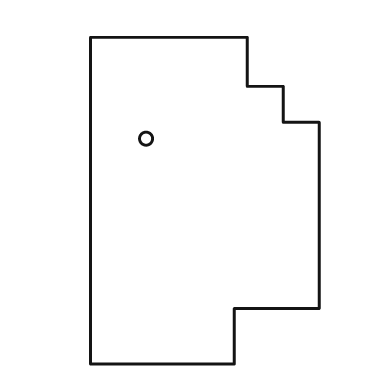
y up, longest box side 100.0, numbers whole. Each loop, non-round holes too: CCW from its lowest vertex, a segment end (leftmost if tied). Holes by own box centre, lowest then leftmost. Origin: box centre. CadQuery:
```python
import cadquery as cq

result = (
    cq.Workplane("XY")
    .moveTo(-35.0, -50.0)
    .lineTo(9.0, -50.0)
    .lineTo(9.0, -33.0)
    .lineTo(35.0, -33.0)
    .lineTo(35.0, 24.0)
    .lineTo(24.0, 24.0)
    .lineTo(24.0, 35.0)
    .lineTo(13.0, 35.0)
    .lineTo(13.0, 50.0)
    .lineTo(-35.0, 50.0)
    .close()
    .moveTo(-18.0, 19.0)
    .circle(2.0)
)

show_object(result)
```